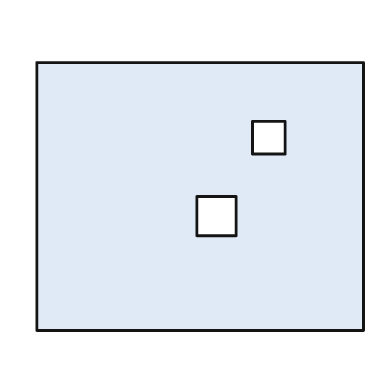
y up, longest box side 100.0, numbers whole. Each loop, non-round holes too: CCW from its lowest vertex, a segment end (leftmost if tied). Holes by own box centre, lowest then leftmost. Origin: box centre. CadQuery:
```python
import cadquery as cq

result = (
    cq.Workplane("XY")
    .moveTo(-50.0, -41.0)
    .lineTo(50.0, -41.0)
    .lineTo(50.0, 41.0)
    .lineTo(-50.0, 41.0)
    .close()
    .moveTo(-1.0, -12.0)
    .lineTo(11.0, -12.0)
    .lineTo(11.0, 0.0)
    .lineTo(-1.0, 0.0)
    .close()
    .moveTo(16.0, 13.0)
    .lineTo(26.0, 13.0)
    .lineTo(26.0, 23.0)
    .lineTo(16.0, 23.0)
    .close()
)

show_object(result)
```